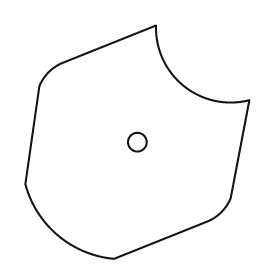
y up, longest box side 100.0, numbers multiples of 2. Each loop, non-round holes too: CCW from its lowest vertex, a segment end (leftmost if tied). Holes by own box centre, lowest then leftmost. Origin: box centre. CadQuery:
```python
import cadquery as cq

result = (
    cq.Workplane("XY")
    .moveTo(-10.0, -50.0)
    .lineTo(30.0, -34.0)
    .threePointArc((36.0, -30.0), (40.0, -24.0))
    .lineTo(48.0, 18.0)
    .threePointArc((20.0, 24.0), (8.0, 50.0))
    .lineTo(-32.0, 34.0)
    .threePointArc((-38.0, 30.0), (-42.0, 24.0))
    .lineTo(-48.0, -18.0)
    .threePointArc((-34.0, -40.0), (-10.0, -50.0))
    .close()
    .moveTo(0.0, 0.0)
    .circle(4.0)
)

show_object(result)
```